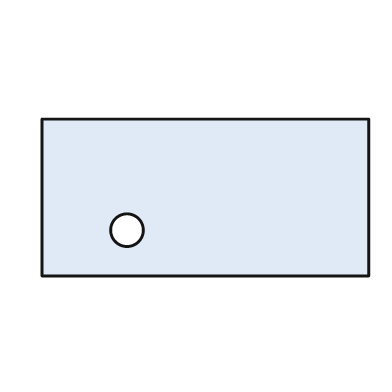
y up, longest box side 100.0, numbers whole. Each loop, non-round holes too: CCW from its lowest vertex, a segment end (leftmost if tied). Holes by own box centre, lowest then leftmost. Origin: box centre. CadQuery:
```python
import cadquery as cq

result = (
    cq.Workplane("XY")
    .moveTo(-50.0, -24.0)
    .lineTo(50.0, -24.0)
    .lineTo(50.0, 24.0)
    .lineTo(-50.0, 24.0)
    .close()
    .moveTo(-24.0, -10.0)
    .circle(5.0)
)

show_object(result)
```